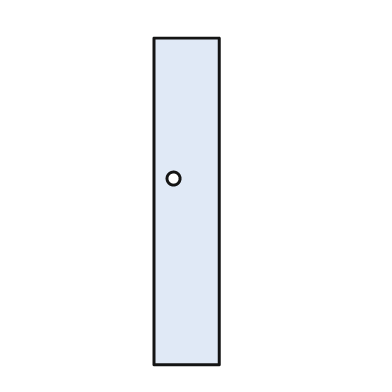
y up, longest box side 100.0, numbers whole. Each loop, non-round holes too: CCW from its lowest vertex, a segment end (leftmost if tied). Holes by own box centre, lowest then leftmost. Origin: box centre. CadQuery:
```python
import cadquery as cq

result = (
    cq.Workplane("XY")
    .moveTo(-10.0, -50.0)
    .lineTo(10.0, -50.0)
    .lineTo(10.0, 50.0)
    .lineTo(-10.0, 50.0)
    .close()
    .moveTo(-4.0, 7.0)
    .circle(2.0)
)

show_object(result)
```